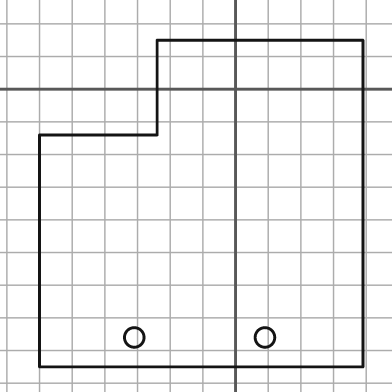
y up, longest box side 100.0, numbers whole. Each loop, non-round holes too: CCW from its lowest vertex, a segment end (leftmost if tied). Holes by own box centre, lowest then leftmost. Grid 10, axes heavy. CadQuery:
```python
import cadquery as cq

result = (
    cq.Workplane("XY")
    .moveTo(-60.0, -85.0)
    .lineTo(39.0, -85.0)
    .lineTo(39.0, 15.0)
    .lineTo(-24.0, 15.0)
    .lineTo(-24.0, -14.0)
    .lineTo(-60.0, -14.0)
    .close()
    .moveTo(-31.0, -76.0)
    .circle(3.0)
    .moveTo(9.0, -76.0)
    .circle(3.0)
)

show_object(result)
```